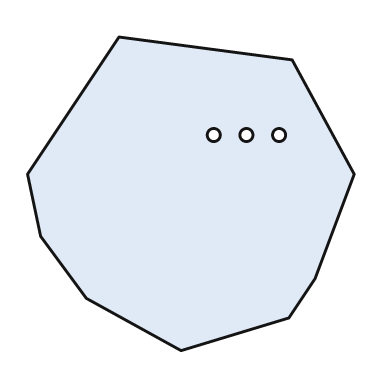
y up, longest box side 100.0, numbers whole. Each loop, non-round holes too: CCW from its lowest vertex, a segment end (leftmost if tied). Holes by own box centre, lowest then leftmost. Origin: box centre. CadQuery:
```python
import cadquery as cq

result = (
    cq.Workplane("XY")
    .moveTo(-3.0, -48.0)
    .lineTo(30.0, -38.0)
    .lineTo(38.0, -26.0)
    .lineTo(50.0, 6.0)
    .lineTo(31.0, 41.0)
    .lineTo(-22.0, 48.0)
    .lineTo(-50.0, 6.0)
    .lineTo(-46.0, -13.0)
    .lineTo(-32.0, -32.0)
    .close()
    .moveTo(7.0, 18.0)
    .circle(2.0)
    .moveTo(17.0, 18.0)
    .circle(2.0)
    .moveTo(27.0, 18.0)
    .circle(2.0)
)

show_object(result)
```